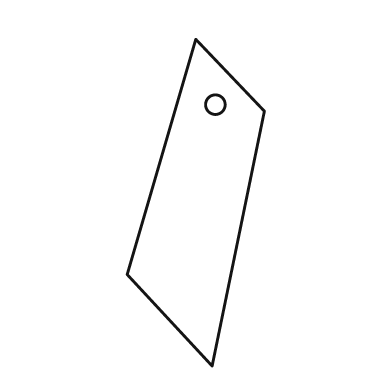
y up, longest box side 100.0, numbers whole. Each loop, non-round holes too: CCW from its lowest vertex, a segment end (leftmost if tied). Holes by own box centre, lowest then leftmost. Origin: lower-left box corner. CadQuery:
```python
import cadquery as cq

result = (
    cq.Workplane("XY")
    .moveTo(26.0, 0.0)
    .lineTo(42.0, 78.0)
    .lineTo(21.0, 100.0)
    .lineTo(0.0, 28.0)
    .close()
    .moveTo(27.0, 80.0)
    .circle(3.0)
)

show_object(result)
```